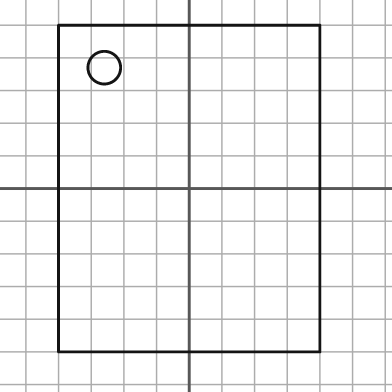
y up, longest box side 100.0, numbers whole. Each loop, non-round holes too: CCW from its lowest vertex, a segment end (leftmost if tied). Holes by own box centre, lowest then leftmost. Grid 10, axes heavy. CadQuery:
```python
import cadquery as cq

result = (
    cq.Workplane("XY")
    .moveTo(-40.0, -50.0)
    .lineTo(40.0, -50.0)
    .lineTo(40.0, 50.0)
    .lineTo(-40.0, 50.0)
    .close()
    .moveTo(-26.0, 37.0)
    .circle(5.0)
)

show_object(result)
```